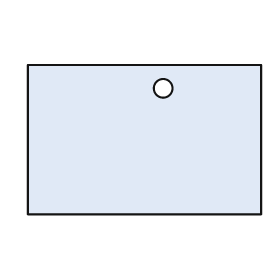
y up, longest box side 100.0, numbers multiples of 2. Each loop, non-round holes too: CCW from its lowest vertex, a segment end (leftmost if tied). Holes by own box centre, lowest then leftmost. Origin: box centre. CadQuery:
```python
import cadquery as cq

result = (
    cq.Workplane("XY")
    .moveTo(-50.0, -32.0)
    .lineTo(50.0, -32.0)
    .lineTo(50.0, 32.0)
    .lineTo(-50.0, 32.0)
    .close()
    .moveTo(8.0, 22.0)
    .circle(4.0)
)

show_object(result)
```